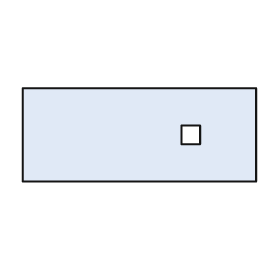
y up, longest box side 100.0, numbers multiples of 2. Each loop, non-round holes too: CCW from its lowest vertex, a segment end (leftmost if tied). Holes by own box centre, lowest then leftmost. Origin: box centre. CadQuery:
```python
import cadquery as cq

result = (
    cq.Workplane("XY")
    .moveTo(-50.0, -20.0)
    .lineTo(50.0, -20.0)
    .lineTo(50.0, 20.0)
    .lineTo(-50.0, 20.0)
    .close()
    .moveTo(18.0, -4.0)
    .lineTo(26.0, -4.0)
    .lineTo(26.0, 4.0)
    .lineTo(18.0, 4.0)
    .close()
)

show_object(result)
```